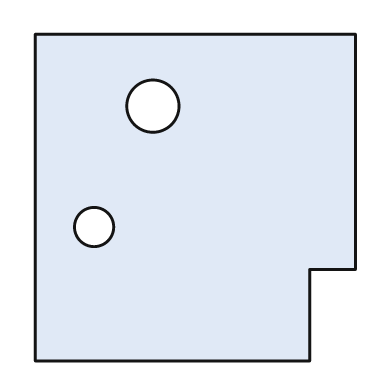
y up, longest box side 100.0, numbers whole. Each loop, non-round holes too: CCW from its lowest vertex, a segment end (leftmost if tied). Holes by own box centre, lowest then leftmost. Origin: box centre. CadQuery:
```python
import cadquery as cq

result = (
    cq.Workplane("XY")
    .moveTo(-49.0, -50.0)
    .lineTo(35.0, -50.0)
    .lineTo(35.0, -22.0)
    .lineTo(49.0, -22.0)
    .lineTo(49.0, 50.0)
    .lineTo(-49.0, 50.0)
    .close()
    .moveTo(-31.0, -9.0)
    .circle(6.0)
    .moveTo(-13.0, 28.0)
    .circle(8.0)
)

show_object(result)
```